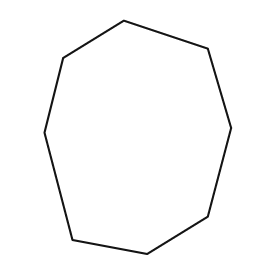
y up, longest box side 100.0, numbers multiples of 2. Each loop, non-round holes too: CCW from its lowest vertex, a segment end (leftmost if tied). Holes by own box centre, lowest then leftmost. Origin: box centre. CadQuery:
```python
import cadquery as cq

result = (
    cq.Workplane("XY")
    .moveTo(4.0, -50.0)
    .lineTo(30.0, -34.0)
    .lineTo(40.0, 4.0)
    .lineTo(30.0, 38.0)
    .lineTo(-6.0, 50.0)
    .lineTo(-32.0, 34.0)
    .lineTo(-40.0, 2.0)
    .lineTo(-28.0, -44.0)
    .close()
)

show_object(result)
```